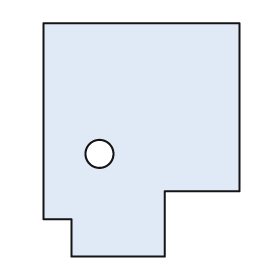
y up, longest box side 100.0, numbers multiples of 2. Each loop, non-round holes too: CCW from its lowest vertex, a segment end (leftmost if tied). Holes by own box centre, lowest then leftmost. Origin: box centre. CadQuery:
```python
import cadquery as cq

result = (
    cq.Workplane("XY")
    .moveTo(-30.0, -50.0)
    .lineTo(10.0, -50.0)
    .lineTo(10.0, -22.0)
    .lineTo(42.0, -22.0)
    .lineTo(42.0, 50.0)
    .lineTo(-42.0, 50.0)
    .lineTo(-42.0, -34.0)
    .lineTo(-30.0, -34.0)
    .close()
    .moveTo(-18.0, -6.0)
    .circle(6.0)
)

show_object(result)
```